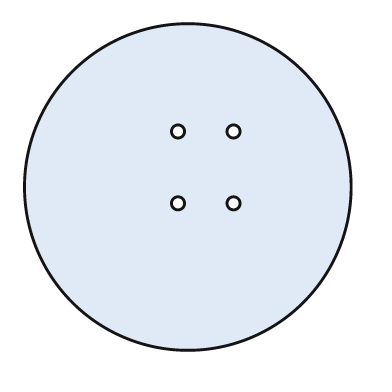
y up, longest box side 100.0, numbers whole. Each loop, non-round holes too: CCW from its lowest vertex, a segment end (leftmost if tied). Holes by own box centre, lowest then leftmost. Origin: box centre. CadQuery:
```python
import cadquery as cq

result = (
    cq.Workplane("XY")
    .moveTo(0.0, 0.0)
    .circle(50.0)
    .moveTo(-3.0, -5.0)
    .circle(2.0)
    .moveTo(14.0, -5.0)
    .circle(2.0)
    .moveTo(-3.0, 17.0)
    .circle(2.0)
    .moveTo(14.0, 17.0)
    .circle(2.0)
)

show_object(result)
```